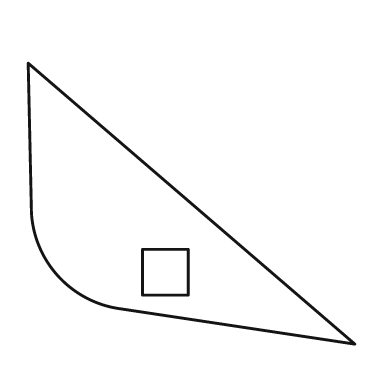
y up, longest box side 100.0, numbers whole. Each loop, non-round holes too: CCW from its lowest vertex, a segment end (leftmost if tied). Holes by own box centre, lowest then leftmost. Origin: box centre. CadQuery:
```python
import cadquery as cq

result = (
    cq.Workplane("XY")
    .moveTo(50.0, -43.0)
    .lineTo(-50.0, 43.0)
    .lineTo(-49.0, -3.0)
    .threePointArc((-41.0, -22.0), (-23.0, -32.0))
    .close()
    .moveTo(-15.0, -28.0)
    .lineTo(-1.0, -28.0)
    .lineTo(-1.0, -14.0)
    .lineTo(-15.0, -14.0)
    .close()
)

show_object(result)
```